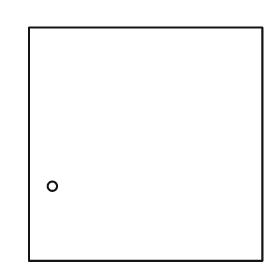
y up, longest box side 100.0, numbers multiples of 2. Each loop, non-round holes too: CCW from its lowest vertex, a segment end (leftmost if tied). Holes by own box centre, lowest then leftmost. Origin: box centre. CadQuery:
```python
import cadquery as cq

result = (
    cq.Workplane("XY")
    .moveTo(-50.0, -50.0)
    .lineTo(50.0, -50.0)
    .lineTo(50.0, 50.0)
    .lineTo(-50.0, 50.0)
    .close()
    .moveTo(-40.0, -18.0)
    .circle(2.0)
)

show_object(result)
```